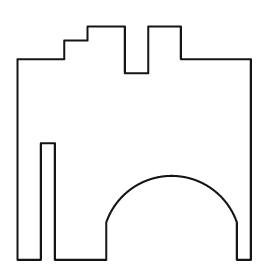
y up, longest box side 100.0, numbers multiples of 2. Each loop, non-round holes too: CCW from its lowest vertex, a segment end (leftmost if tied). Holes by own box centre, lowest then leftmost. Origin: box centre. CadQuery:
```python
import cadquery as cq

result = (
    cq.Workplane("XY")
    .moveTo(-50.0, -50.0)
    .lineTo(-40.0, -50.0)
    .lineTo(-40.0, 0.0)
    .lineTo(-34.0, 0.0)
    .lineTo(-34.0, -50.0)
    .lineTo(-12.0, -50.0)
    .lineTo(-12.0, -34.0)
    .threePointArc((16.0, -14.0), (44.0, -34.0))
    .lineTo(44.0, -50.0)
    .lineTo(50.0, -50.0)
    .lineTo(50.0, 36.0)
    .lineTo(20.0, 36.0)
    .lineTo(20.0, 50.0)
    .lineTo(6.0, 50.0)
    .lineTo(6.0, 30.0)
    .lineTo(-4.0, 30.0)
    .lineTo(-4.0, 50.0)
    .lineTo(-20.0, 50.0)
    .lineTo(-20.0, 44.0)
    .lineTo(-30.0, 44.0)
    .lineTo(-30.0, 36.0)
    .lineTo(-50.0, 36.0)
    .close()
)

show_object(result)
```